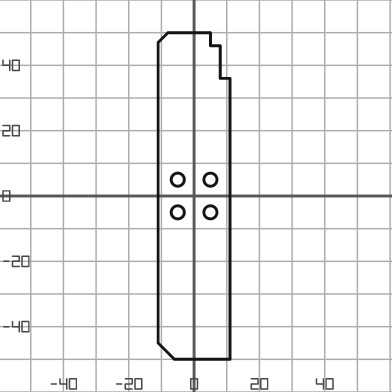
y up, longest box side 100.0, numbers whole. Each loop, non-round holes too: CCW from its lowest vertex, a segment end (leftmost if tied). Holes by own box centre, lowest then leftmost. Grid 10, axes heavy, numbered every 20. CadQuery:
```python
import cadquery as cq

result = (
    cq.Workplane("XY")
    .moveTo(-6.0, -50.0)
    .lineTo(11.0, -50.0)
    .lineTo(11.0, 36.0)
    .lineTo(8.0, 36.0)
    .lineTo(8.0, 46.0)
    .lineTo(5.0, 46.0)
    .lineTo(5.0, 50.0)
    .lineTo(-8.0, 50.0)
    .lineTo(-11.0, 47.0)
    .lineTo(-11.0, -45.0)
    .close()
    .moveTo(-5.0, -5.0)
    .circle(2.0)
    .moveTo(5.0, -5.0)
    .circle(2.0)
    .moveTo(-5.0, 5.0)
    .circle(2.0)
    .moveTo(5.0, 5.0)
    .circle(2.0)
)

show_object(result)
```